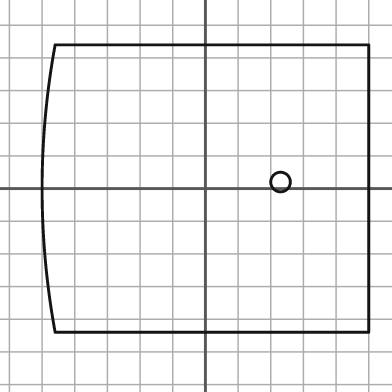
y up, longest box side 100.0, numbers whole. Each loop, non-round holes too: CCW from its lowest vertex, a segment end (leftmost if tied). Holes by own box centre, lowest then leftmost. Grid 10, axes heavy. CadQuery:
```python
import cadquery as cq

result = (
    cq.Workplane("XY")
    .moveTo(-46.0, -44.0)
    .lineTo(50.0, -44.0)
    .lineTo(50.0, 44.0)
    .lineTo(-46.0, 44.0)
    .threePointArc((-50.0, 0.0), (-46.0, -44.0))
    .close()
    .moveTo(23.0, 2.0)
    .circle(3.0)
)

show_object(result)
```